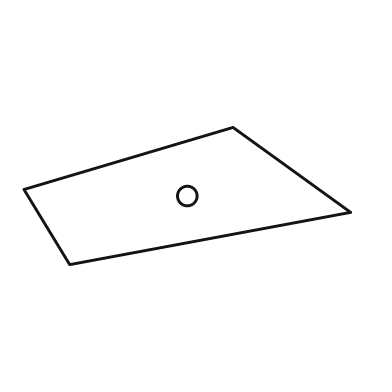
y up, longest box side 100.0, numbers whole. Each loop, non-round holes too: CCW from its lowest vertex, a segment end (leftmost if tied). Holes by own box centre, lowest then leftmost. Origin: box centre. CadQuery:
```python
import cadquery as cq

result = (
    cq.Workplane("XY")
    .moveTo(-36.0, -21.0)
    .lineTo(50.0, -5.0)
    .lineTo(14.0, 21.0)
    .lineTo(-50.0, 2.0)
    .close()
    .moveTo(0.0, 0.0)
    .circle(3.0)
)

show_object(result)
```